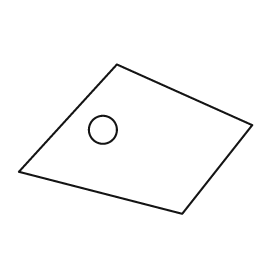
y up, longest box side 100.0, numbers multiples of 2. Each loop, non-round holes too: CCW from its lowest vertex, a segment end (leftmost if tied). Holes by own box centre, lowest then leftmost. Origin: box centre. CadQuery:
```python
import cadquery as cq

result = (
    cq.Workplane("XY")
    .moveTo(20.0, -32.0)
    .lineTo(50.0, 6.0)
    .lineTo(-8.0, 32.0)
    .lineTo(-50.0, -14.0)
    .close()
    .moveTo(-14.0, 4.0)
    .circle(6.0)
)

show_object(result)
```